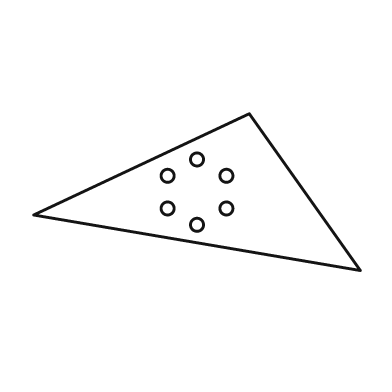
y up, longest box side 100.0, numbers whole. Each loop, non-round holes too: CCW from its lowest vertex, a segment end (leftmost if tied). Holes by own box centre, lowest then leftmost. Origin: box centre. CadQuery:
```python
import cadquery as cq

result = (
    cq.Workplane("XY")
    .moveTo(50.0, -24.0)
    .lineTo(16.0, 24.0)
    .lineTo(-50.0, -7.0)
    .close()
    .moveTo(0.0, -10.0)
    .circle(2.0)
    .moveTo(-9.0, -5.0)
    .circle(2.0)
    .moveTo(9.0, -5.0)
    .circle(2.0)
    .moveTo(-9.0, 5.0)
    .circle(2.0)
    .moveTo(9.0, 5.0)
    .circle(2.0)
    .moveTo(0.0, 10.0)
    .circle(2.0)
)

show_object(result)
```